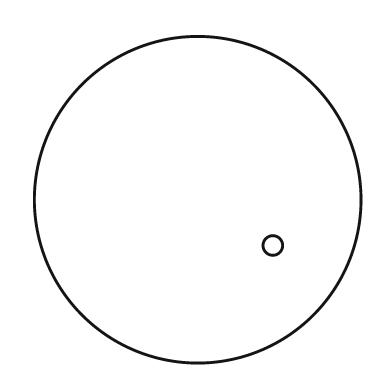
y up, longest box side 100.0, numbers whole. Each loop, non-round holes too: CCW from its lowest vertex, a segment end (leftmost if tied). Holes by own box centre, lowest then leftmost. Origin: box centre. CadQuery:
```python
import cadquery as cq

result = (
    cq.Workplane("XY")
    .moveTo(0.0, 0.0)
    .circle(50.0)
    .moveTo(23.0, -14.0)
    .circle(3.0)
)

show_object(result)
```